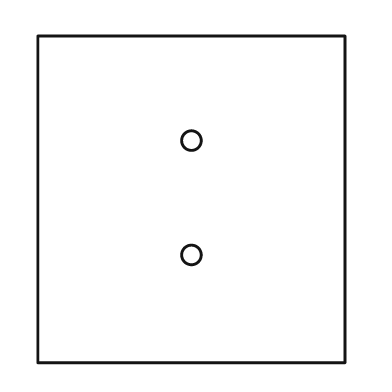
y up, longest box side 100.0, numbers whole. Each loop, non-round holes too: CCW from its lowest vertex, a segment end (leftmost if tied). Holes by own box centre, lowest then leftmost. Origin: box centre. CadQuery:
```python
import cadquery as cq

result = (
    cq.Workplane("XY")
    .moveTo(-47.0, -50.0)
    .lineTo(47.0, -50.0)
    .lineTo(47.0, 50.0)
    .lineTo(-47.0, 50.0)
    .close()
    .moveTo(0.0, -17.0)
    .circle(3.0)
    .moveTo(0.0, 18.0)
    .circle(3.0)
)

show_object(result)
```